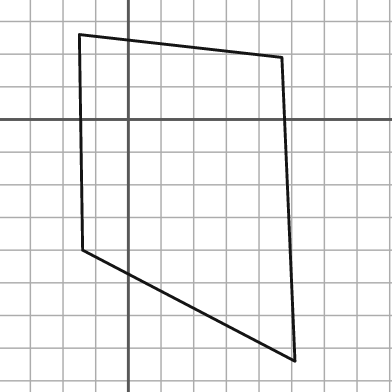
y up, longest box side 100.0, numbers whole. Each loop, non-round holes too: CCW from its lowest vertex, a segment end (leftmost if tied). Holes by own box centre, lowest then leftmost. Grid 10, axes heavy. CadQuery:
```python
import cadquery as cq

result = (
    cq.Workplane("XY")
    .moveTo(51.0, -74.0)
    .lineTo(47.0, 19.0)
    .lineTo(-15.0, 26.0)
    .lineTo(-14.0, -40.0)
    .close()
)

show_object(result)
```